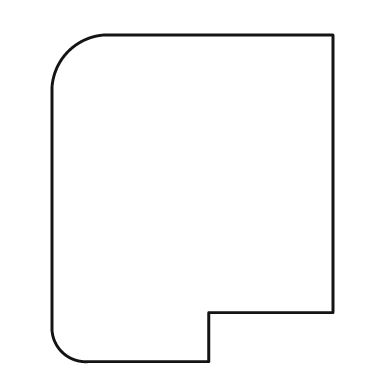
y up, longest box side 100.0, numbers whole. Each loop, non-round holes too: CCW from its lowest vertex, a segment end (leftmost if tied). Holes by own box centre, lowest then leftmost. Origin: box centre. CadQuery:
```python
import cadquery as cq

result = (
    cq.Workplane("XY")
    .moveTo(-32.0, -50.0)
    .lineTo(5.0, -50.0)
    .lineTo(5.0, -35.0)
    .lineTo(43.0, -35.0)
    .lineTo(43.0, 50.0)
    .lineTo(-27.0, 50.0)
    .threePointArc((-38.0, 45.0), (-43.0, 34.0))
    .lineTo(-43.0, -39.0)
    .threePointArc((-40.0, -47.0), (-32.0, -50.0))
    .close()
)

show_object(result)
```